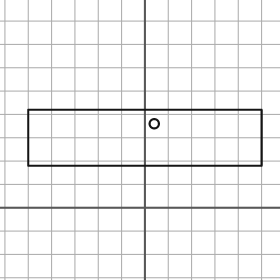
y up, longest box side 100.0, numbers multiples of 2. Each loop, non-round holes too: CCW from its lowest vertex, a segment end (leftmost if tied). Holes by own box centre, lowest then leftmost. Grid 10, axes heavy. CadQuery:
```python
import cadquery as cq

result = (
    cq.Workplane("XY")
    .moveTo(-50.0, 18.0)
    .lineTo(50.0, 18.0)
    .lineTo(50.0, 42.0)
    .lineTo(-50.0, 42.0)
    .close()
    .moveTo(4.0, 36.0)
    .circle(2.0)
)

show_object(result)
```